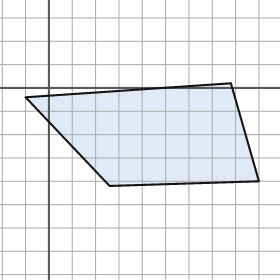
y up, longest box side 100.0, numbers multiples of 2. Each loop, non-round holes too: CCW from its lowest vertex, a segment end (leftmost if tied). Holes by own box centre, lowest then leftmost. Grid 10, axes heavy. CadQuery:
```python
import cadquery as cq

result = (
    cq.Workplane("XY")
    .moveTo(26.0, -42.0)
    .lineTo(90.0, -40.0)
    .lineTo(78.0, 2.0)
    .lineTo(-10.0, -4.0)
    .close()
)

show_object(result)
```